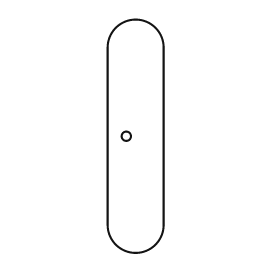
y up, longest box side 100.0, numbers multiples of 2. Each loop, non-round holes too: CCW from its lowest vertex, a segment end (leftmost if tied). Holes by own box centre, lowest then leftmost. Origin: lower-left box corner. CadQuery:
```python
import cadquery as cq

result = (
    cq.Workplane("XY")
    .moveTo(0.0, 12.0)
    .threePointArc((12.0, 0.0), (24.0, 12.0))
    .lineTo(24.0, 88.0)
    .threePointArc((12.0, 100.0), (0.0, 88.0))
    .close()
    .moveTo(8.0, 50.0)
    .circle(2.0)
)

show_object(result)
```